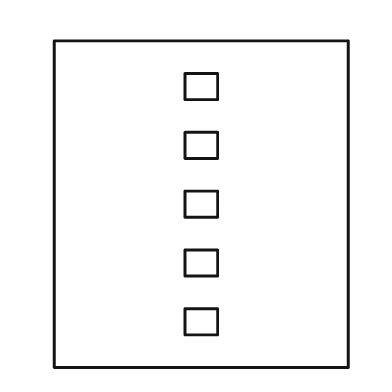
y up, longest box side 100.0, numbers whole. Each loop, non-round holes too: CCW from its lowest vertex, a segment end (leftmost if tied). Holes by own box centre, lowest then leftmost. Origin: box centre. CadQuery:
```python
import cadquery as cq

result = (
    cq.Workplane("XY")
    .moveTo(-45.0, -50.0)
    .lineTo(45.0, -50.0)
    .lineTo(45.0, 50.0)
    .lineTo(-45.0, 50.0)
    .close()
    .moveTo(-5.0, -40.0)
    .lineTo(5.0, -40.0)
    .lineTo(5.0, -32.0)
    .lineTo(-5.0, -32.0)
    .close()
    .moveTo(-5.0, -22.0)
    .lineTo(5.0, -22.0)
    .lineTo(5.0, -14.0)
    .lineTo(-5.0, -14.0)
    .close()
    .moveTo(-5.0, -4.0)
    .lineTo(5.0, -4.0)
    .lineTo(5.0, 4.0)
    .lineTo(-5.0, 4.0)
    .close()
    .moveTo(-5.0, 14.0)
    .lineTo(5.0, 14.0)
    .lineTo(5.0, 22.0)
    .lineTo(-5.0, 22.0)
    .close()
    .moveTo(-5.0, 32.0)
    .lineTo(5.0, 32.0)
    .lineTo(5.0, 40.0)
    .lineTo(-5.0, 40.0)
    .close()
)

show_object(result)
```